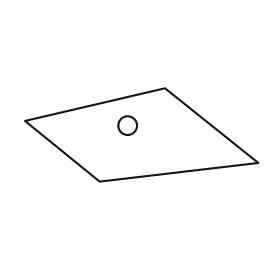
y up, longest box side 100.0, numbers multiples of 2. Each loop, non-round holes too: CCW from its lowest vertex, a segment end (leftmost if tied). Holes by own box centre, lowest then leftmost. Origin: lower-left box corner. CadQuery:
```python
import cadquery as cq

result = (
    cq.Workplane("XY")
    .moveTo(32.0, 0.0)
    .lineTo(100.0, 8.0)
    .lineTo(60.0, 40.0)
    .lineTo(0.0, 26.0)
    .close()
    .moveTo(44.0, 24.0)
    .circle(4.0)
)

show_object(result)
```